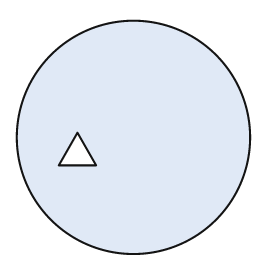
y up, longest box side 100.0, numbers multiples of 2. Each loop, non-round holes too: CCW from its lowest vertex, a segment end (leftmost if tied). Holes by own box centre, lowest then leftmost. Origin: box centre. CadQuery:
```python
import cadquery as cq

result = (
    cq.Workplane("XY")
    .moveTo(0.0, 0.0)
    .circle(50.0)
    .moveTo(-32.0, -12.0)
    .lineTo(-16.0, -12.0)
    .lineTo(-24.0, 2.0)
    .close()
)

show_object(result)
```